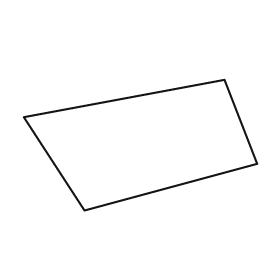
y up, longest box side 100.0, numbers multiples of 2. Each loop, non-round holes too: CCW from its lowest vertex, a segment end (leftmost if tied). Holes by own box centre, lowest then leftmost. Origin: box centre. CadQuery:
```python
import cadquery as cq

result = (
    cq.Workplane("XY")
    .moveTo(-24.0, -28.0)
    .lineTo(50.0, -8.0)
    .lineTo(36.0, 28.0)
    .lineTo(-50.0, 12.0)
    .close()
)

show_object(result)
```